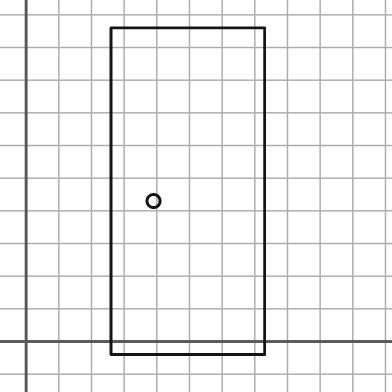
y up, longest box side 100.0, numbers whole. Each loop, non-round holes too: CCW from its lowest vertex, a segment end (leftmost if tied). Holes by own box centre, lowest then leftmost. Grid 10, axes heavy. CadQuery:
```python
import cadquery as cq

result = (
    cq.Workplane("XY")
    .moveTo(26.0, -4.0)
    .lineTo(73.0, -4.0)
    .lineTo(73.0, 96.0)
    .lineTo(26.0, 96.0)
    .close()
    .moveTo(39.0, 43.0)
    .circle(2.0)
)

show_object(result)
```